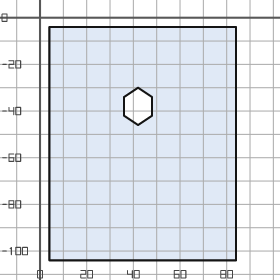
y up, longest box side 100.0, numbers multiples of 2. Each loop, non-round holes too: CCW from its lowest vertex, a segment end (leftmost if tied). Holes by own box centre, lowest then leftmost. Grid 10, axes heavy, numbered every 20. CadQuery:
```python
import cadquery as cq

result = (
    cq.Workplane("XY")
    .moveTo(4.0, -104.0)
    .lineTo(84.0, -104.0)
    .lineTo(84.0, -4.0)
    .lineTo(4.0, -4.0)
    .close()
    .moveTo(42.0, -46.0)
    .lineTo(48.0, -42.0)
    .lineTo(48.0, -34.0)
    .lineTo(42.0, -30.0)
    .lineTo(36.0, -34.0)
    .lineTo(36.0, -42.0)
    .close()
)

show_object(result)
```